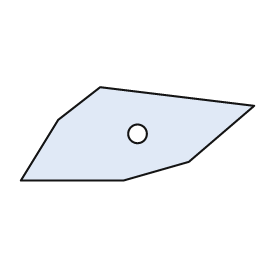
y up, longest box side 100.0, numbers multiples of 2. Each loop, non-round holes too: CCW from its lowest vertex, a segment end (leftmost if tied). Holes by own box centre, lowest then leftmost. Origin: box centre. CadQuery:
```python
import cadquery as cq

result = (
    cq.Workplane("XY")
    .moveTo(-50.0, -20.0)
    .lineTo(-6.0, -20.0)
    .lineTo(22.0, -12.0)
    .lineTo(50.0, 12.0)
    .lineTo(-16.0, 20.0)
    .lineTo(-34.0, 6.0)
    .close()
    .moveTo(0.0, 0.0)
    .circle(4.0)
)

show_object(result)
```